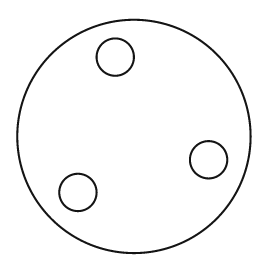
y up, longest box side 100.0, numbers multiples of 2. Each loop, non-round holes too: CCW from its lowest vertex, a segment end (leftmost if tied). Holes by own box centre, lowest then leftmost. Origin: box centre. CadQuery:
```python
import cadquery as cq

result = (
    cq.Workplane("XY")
    .moveTo(0.0, 0.0)
    .circle(50.0)
    .moveTo(-24.0, -24.0)
    .circle(8.0)
    .moveTo(32.0, -10.0)
    .circle(8.0)
    .moveTo(-8.0, 34.0)
    .circle(8.0)
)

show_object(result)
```